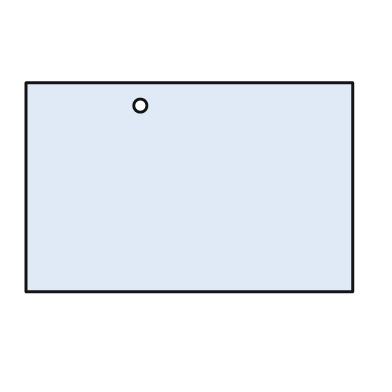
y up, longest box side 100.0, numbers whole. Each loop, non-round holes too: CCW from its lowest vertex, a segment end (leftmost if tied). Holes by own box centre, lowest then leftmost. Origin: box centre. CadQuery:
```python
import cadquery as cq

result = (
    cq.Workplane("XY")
    .moveTo(-50.0, -32.0)
    .lineTo(50.0, -32.0)
    .lineTo(50.0, 32.0)
    .lineTo(-50.0, 32.0)
    .close()
    .moveTo(-15.0, 25.0)
    .circle(2.0)
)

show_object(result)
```